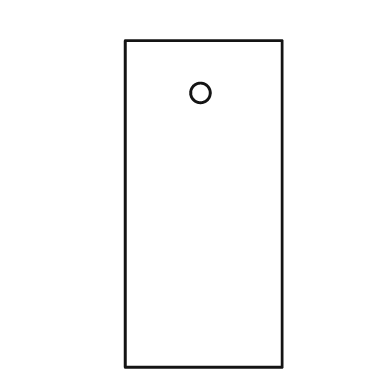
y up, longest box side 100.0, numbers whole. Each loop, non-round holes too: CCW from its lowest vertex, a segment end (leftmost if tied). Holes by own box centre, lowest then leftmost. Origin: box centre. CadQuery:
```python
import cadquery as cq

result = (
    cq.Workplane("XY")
    .moveTo(-24.0, -50.0)
    .lineTo(24.0, -50.0)
    .lineTo(24.0, 50.0)
    .lineTo(-24.0, 50.0)
    .close()
    .moveTo(-1.0, 34.0)
    .circle(3.0)
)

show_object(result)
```